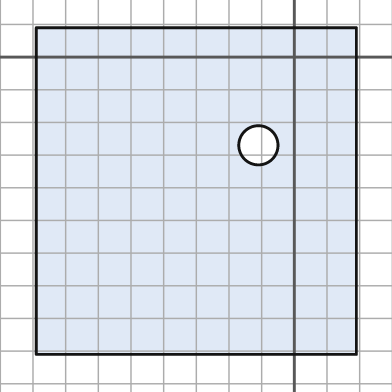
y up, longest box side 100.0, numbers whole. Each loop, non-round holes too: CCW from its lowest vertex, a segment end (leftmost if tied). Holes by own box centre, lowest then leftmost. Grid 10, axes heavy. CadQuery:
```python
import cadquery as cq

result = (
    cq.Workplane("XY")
    .moveTo(-79.0, -91.0)
    .lineTo(19.0, -91.0)
    .lineTo(19.0, 9.0)
    .lineTo(-79.0, 9.0)
    .close()
    .moveTo(-11.0, -27.0)
    .circle(6.0)
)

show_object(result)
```